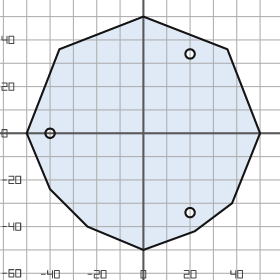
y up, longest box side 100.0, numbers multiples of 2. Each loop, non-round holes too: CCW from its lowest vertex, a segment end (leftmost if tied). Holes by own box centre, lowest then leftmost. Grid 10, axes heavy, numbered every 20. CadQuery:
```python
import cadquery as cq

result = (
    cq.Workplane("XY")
    .moveTo(0.0, -50.0)
    .lineTo(22.0, -42.0)
    .lineTo(38.0, -30.0)
    .lineTo(50.0, 0.0)
    .lineTo(36.0, 36.0)
    .lineTo(0.0, 50.0)
    .lineTo(-36.0, 36.0)
    .lineTo(-50.0, 0.0)
    .lineTo(-40.0, -24.0)
    .lineTo(-24.0, -40.0)
    .close()
    .moveTo(20.0, -34.0)
    .circle(2.0)
    .moveTo(-40.0, 0.0)
    .circle(2.0)
    .moveTo(20.0, 34.0)
    .circle(2.0)
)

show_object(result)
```